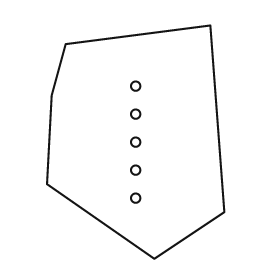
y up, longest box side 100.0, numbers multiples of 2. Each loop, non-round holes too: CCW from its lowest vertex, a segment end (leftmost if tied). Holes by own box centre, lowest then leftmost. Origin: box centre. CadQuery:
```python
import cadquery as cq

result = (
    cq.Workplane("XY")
    .moveTo(8.0, -50.0)
    .lineTo(38.0, -30.0)
    .lineTo(32.0, 50.0)
    .lineTo(-30.0, 42.0)
    .lineTo(-36.0, 20.0)
    .lineTo(-38.0, -18.0)
    .close()
    .moveTo(0.0, -24.0)
    .circle(2.0)
    .moveTo(0.0, -12.0)
    .circle(2.0)
    .moveTo(0.0, 0.0)
    .circle(2.0)
    .moveTo(0.0, 12.0)
    .circle(2.0)
    .moveTo(0.0, 24.0)
    .circle(2.0)
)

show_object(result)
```